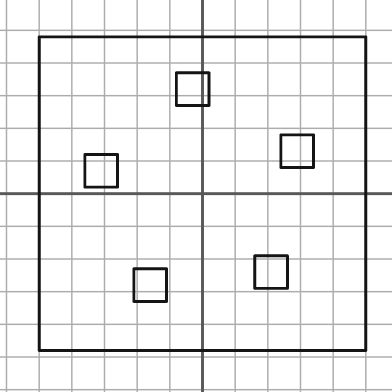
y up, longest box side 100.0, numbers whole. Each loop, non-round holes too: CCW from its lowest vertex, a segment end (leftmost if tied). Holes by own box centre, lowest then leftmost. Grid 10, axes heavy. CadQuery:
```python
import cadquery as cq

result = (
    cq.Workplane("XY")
    .moveTo(-50.0, -48.0)
    .lineTo(50.0, -48.0)
    .lineTo(50.0, 48.0)
    .lineTo(-50.0, 48.0)
    .close()
    .moveTo(-21.0, -33.0)
    .lineTo(-11.0, -33.0)
    .lineTo(-11.0, -23.0)
    .lineTo(-21.0, -23.0)
    .close()
    .moveTo(16.0, -29.0)
    .lineTo(26.0, -29.0)
    .lineTo(26.0, -19.0)
    .lineTo(16.0, -19.0)
    .close()
    .moveTo(-36.0, 2.0)
    .lineTo(-26.0, 2.0)
    .lineTo(-26.0, 12.0)
    .lineTo(-36.0, 12.0)
    .close()
    .moveTo(24.0, 8.0)
    .lineTo(34.0, 8.0)
    .lineTo(34.0, 18.0)
    .lineTo(24.0, 18.0)
    .close()
    .moveTo(-8.0, 27.0)
    .lineTo(2.0, 27.0)
    .lineTo(2.0, 37.0)
    .lineTo(-8.0, 37.0)
    .close()
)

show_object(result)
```